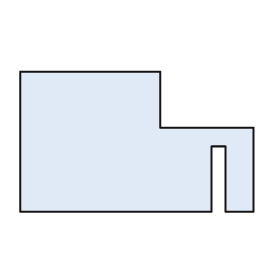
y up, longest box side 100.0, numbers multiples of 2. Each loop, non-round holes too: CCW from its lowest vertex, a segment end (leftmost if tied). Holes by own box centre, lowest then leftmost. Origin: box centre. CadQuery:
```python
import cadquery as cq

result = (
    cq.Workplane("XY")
    .moveTo(-50.0, -30.0)
    .lineTo(32.0, -30.0)
    .lineTo(32.0, -2.0)
    .lineTo(38.0, -2.0)
    .lineTo(38.0, -30.0)
    .lineTo(50.0, -30.0)
    .lineTo(50.0, 6.0)
    .lineTo(10.0, 6.0)
    .lineTo(10.0, 30.0)
    .lineTo(-50.0, 30.0)
    .close()
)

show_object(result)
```